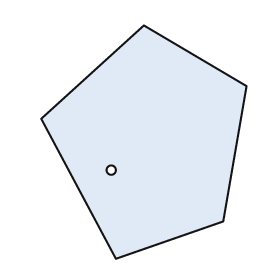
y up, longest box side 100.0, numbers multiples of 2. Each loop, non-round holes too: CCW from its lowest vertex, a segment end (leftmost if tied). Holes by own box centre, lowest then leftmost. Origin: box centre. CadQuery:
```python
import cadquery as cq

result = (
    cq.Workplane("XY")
    .moveTo(-12.0, -50.0)
    .lineTo(34.0, -34.0)
    .lineTo(44.0, 24.0)
    .lineTo(0.0, 50.0)
    .lineTo(-44.0, 10.0)
    .close()
    .moveTo(-14.0, -12.0)
    .circle(2.0)
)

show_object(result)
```